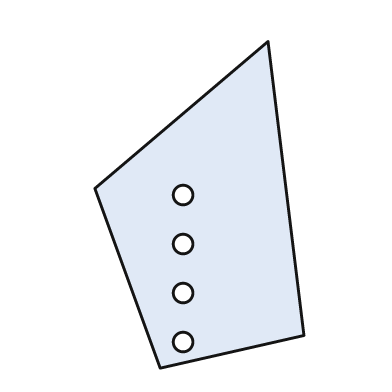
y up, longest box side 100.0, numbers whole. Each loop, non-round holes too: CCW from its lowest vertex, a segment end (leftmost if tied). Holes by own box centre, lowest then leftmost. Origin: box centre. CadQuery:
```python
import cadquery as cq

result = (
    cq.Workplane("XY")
    .moveTo(-12.0, -50.0)
    .lineTo(32.0, -40.0)
    .lineTo(21.0, 50.0)
    .lineTo(-32.0, 5.0)
    .close()
    .moveTo(-5.0, -42.0)
    .circle(3.0)
    .moveTo(-5.0, -27.0)
    .circle(3.0)
    .moveTo(-5.0, -12.0)
    .circle(3.0)
    .moveTo(-5.0, 3.0)
    .circle(3.0)
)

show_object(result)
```